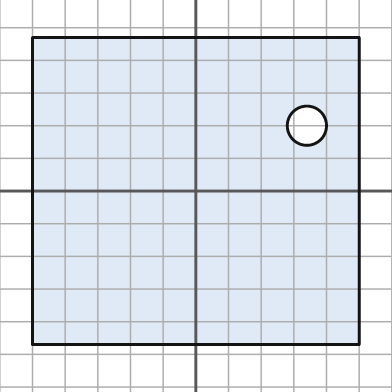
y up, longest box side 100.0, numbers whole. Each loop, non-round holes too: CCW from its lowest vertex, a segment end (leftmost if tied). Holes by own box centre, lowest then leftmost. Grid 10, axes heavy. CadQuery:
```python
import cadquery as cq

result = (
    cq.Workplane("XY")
    .moveTo(-50.0, -47.0)
    .lineTo(50.0, -47.0)
    .lineTo(50.0, 47.0)
    .lineTo(-50.0, 47.0)
    .close()
    .moveTo(34.0, 20.0)
    .circle(6.0)
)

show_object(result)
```